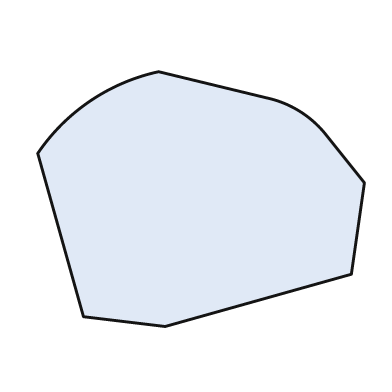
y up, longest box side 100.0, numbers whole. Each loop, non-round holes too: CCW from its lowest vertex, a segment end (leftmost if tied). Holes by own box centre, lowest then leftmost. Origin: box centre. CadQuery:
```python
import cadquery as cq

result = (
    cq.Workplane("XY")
    .moveTo(-11.0, -39.0)
    .lineTo(46.0, -23.0)
    .lineTo(50.0, 5.0)
    .lineTo(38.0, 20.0)
    .threePointArc((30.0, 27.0), (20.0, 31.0))
    .lineTo(-13.0, 39.0)
    .threePointArc((-34.0, 30.0), (-50.0, 14.0))
    .lineTo(-36.0, -36.0)
    .close()
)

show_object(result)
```